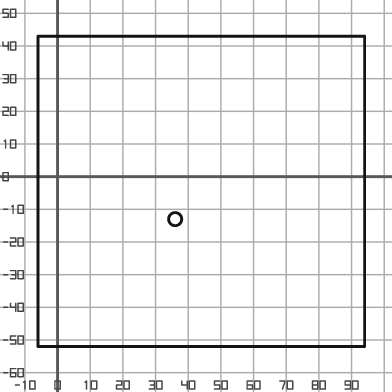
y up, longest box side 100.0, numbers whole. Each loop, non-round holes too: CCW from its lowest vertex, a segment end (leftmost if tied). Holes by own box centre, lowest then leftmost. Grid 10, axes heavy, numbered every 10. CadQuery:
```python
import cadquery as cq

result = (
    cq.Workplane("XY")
    .moveTo(-6.0, -52.0)
    .lineTo(94.0, -52.0)
    .lineTo(94.0, 43.0)
    .lineTo(-6.0, 43.0)
    .close()
    .moveTo(36.0, -13.0)
    .circle(2.0)
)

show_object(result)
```